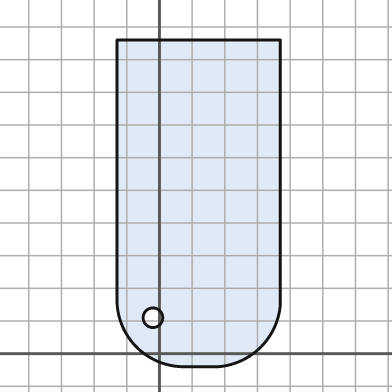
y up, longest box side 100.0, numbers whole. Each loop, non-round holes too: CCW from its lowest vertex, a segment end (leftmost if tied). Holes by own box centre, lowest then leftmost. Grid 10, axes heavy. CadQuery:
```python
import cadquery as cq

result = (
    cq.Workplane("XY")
    .moveTo(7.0, -4.0)
    .lineTo(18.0, -4.0)
    .threePointArc((31.0, 2.0), (37.0, 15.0))
    .lineTo(37.0, 96.0)
    .lineTo(-13.0, 96.0)
    .lineTo(-13.0, 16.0)
    .threePointArc((-7.0, 2.0), (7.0, -4.0))
    .close()
    .moveTo(-2.0, 11.0)
    .circle(3.0)
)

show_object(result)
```